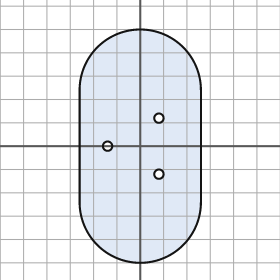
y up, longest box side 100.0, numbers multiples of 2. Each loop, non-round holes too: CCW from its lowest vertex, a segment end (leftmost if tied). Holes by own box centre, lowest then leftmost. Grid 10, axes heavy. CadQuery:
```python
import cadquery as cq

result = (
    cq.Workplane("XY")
    .moveTo(-26.0, -24.0)
    .threePointArc((0.0, -50.0), (26.0, -24.0))
    .lineTo(26.0, 24.0)
    .threePointArc((0.0, 50.0), (-26.0, 24.0))
    .close()
    .moveTo(8.0, -12.0)
    .circle(2.0)
    .moveTo(-14.0, 0.0)
    .circle(2.0)
    .moveTo(8.0, 12.0)
    .circle(2.0)
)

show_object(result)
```